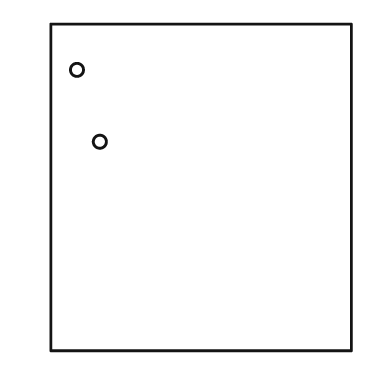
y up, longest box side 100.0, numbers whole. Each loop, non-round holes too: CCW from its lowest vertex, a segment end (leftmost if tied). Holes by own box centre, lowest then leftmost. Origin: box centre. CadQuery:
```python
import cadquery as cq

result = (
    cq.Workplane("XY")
    .moveTo(-46.0, -50.0)
    .lineTo(46.0, -50.0)
    .lineTo(46.0, 50.0)
    .lineTo(-46.0, 50.0)
    .close()
    .moveTo(-31.0, 14.0)
    .circle(2.0)
    .moveTo(-38.0, 36.0)
    .circle(2.0)
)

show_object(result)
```